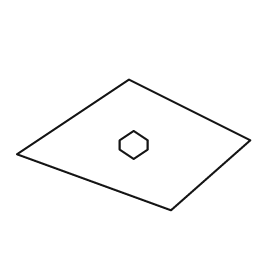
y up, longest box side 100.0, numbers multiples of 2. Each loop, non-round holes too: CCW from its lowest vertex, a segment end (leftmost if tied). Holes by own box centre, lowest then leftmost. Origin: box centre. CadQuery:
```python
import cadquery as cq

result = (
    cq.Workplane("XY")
    .moveTo(16.0, -28.0)
    .lineTo(50.0, 2.0)
    .lineTo(-2.0, 28.0)
    .lineTo(-50.0, -4.0)
    .close()
    .moveTo(0.0, -6.0)
    .lineTo(6.0, -2.0)
    .lineTo(6.0, 2.0)
    .lineTo(0.0, 6.0)
    .lineTo(-6.0, 2.0)
    .lineTo(-6.0, -2.0)
    .close()
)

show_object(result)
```